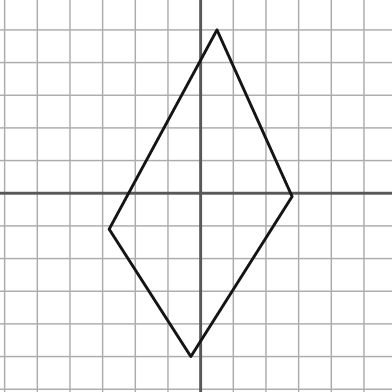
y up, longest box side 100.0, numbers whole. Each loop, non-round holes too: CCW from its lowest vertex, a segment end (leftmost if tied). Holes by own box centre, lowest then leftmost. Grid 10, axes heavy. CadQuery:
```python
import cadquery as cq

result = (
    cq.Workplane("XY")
    .moveTo(-3.0, -50.0)
    .lineTo(28.0, -1.0)
    .lineTo(5.0, 50.0)
    .lineTo(-28.0, -11.0)
    .close()
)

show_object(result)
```